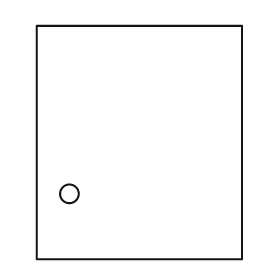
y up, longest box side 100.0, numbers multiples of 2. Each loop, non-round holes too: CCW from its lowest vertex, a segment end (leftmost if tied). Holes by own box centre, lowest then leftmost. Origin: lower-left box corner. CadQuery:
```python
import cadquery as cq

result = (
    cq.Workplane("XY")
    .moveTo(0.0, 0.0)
    .lineTo(88.0, 0.0)
    .lineTo(88.0, 100.0)
    .lineTo(0.0, 100.0)
    .close()
    .moveTo(14.0, 28.0)
    .circle(4.0)
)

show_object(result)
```